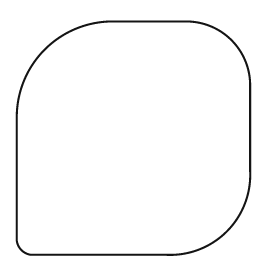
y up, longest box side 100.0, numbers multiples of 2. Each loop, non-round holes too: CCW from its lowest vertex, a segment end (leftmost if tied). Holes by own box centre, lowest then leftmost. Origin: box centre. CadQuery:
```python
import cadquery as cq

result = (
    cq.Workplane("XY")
    .moveTo(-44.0, -50.0)
    .lineTo(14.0, -50.0)
    .threePointArc((40.0, -40.0), (50.0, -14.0))
    .lineTo(50.0, 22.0)
    .threePointArc((42.0, 42.0), (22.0, 50.0))
    .lineTo(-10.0, 50.0)
    .threePointArc((-38.0, 38.0), (-50.0, 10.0))
    .lineTo(-50.0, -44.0)
    .threePointArc((-48.0, -48.0), (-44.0, -50.0))
    .close()
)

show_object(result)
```